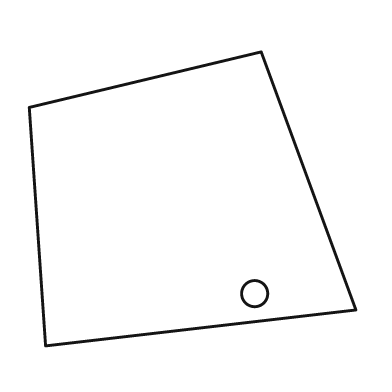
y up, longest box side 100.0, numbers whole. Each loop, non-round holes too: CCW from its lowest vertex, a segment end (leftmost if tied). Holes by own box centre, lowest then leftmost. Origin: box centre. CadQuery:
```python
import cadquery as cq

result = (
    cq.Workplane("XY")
    .moveTo(-45.0, -45.0)
    .lineTo(50.0, -34.0)
    .lineTo(21.0, 45.0)
    .lineTo(-50.0, 28.0)
    .close()
    .moveTo(19.0, -29.0)
    .circle(4.0)
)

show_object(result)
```